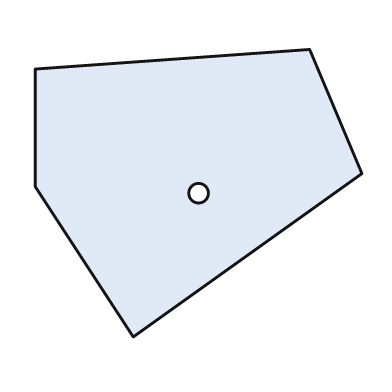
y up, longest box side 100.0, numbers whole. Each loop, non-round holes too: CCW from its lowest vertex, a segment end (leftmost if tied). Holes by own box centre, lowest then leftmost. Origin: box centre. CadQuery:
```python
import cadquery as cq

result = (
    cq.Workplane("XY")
    .moveTo(-20.0, -44.0)
    .lineTo(50.0, 6.0)
    .lineTo(34.0, 44.0)
    .lineTo(-50.0, 38.0)
    .lineTo(-50.0, 2.0)
    .close()
    .moveTo(0.0, 0.0)
    .circle(3.0)
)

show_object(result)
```